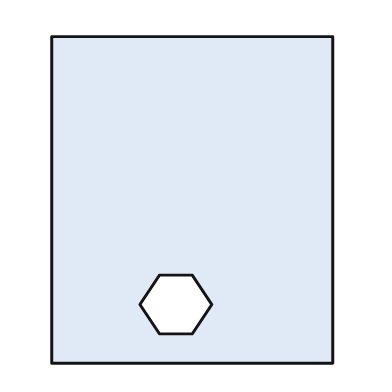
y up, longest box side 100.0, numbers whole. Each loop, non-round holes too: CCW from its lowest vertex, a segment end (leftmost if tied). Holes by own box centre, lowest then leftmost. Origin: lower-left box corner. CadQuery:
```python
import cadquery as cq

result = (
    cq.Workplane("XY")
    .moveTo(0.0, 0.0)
    .lineTo(86.0, 0.0)
    .lineTo(86.0, 100.0)
    .lineTo(0.0, 100.0)
    .close()
    .moveTo(33.0, 9.0)
    .lineTo(43.0, 9.0)
    .lineTo(49.0, 18.0)
    .lineTo(43.0, 27.0)
    .lineTo(33.0, 27.0)
    .lineTo(27.0, 18.0)
    .close()
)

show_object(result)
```